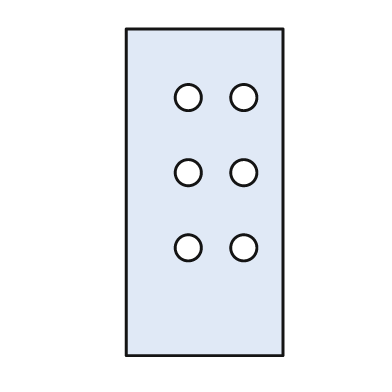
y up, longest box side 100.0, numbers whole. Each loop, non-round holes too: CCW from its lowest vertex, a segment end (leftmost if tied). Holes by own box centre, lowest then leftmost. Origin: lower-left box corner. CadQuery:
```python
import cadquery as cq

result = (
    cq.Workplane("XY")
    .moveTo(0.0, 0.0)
    .lineTo(48.0, 0.0)
    .lineTo(48.0, 100.0)
    .lineTo(0.0, 100.0)
    .close()
    .moveTo(19.0, 33.0)
    .circle(4.0)
    .moveTo(36.0, 33.0)
    .circle(4.0)
    .moveTo(19.0, 56.0)
    .circle(4.0)
    .moveTo(36.0, 56.0)
    .circle(4.0)
    .moveTo(19.0, 79.0)
    .circle(4.0)
    .moveTo(36.0, 79.0)
    .circle(4.0)
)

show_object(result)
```